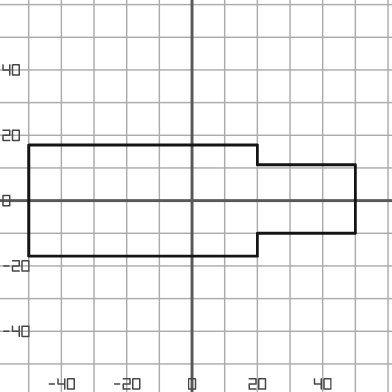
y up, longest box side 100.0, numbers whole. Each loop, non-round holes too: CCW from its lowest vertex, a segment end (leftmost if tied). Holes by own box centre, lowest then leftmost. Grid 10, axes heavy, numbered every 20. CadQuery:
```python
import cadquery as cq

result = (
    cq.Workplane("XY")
    .moveTo(-50.0, -17.0)
    .lineTo(20.0, -17.0)
    .lineTo(20.0, -10.0)
    .lineTo(50.0, -10.0)
    .lineTo(50.0, 11.0)
    .lineTo(20.0, 11.0)
    .lineTo(20.0, 17.0)
    .lineTo(-50.0, 17.0)
    .close()
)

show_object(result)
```